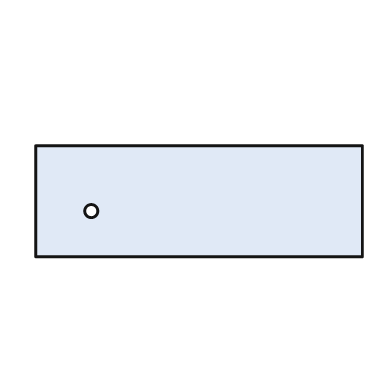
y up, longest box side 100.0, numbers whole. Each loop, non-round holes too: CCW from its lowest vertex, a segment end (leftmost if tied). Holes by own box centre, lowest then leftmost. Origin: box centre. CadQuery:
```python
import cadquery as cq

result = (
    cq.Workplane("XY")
    .moveTo(-50.0, -17.0)
    .lineTo(50.0, -17.0)
    .lineTo(50.0, 17.0)
    .lineTo(-50.0, 17.0)
    .close()
    .moveTo(-33.0, -3.0)
    .circle(2.0)
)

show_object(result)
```